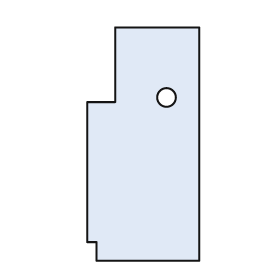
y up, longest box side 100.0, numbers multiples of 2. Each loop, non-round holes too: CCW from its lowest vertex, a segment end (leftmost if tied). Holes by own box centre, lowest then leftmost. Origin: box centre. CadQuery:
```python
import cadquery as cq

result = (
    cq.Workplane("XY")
    .moveTo(-20.0, -50.0)
    .lineTo(24.0, -50.0)
    .lineTo(24.0, 50.0)
    .lineTo(-12.0, 50.0)
    .lineTo(-12.0, 18.0)
    .lineTo(-24.0, 18.0)
    .lineTo(-24.0, -42.0)
    .lineTo(-20.0, -42.0)
    .close()
    .moveTo(10.0, 20.0)
    .circle(4.0)
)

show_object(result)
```